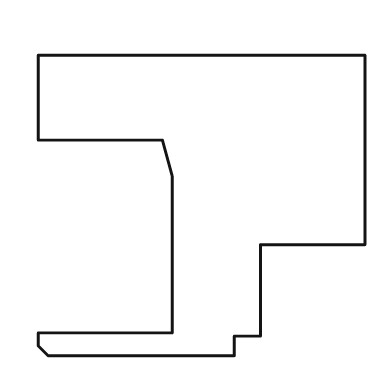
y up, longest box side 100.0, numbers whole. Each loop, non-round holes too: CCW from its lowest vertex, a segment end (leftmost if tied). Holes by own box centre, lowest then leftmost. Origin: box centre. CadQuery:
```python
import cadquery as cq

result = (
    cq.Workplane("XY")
    .moveTo(-47.0, -46.0)
    .lineTo(10.0, -46.0)
    .lineTo(10.0, -40.0)
    .lineTo(18.0, -40.0)
    .lineTo(18.0, -12.0)
    .lineTo(50.0, -12.0)
    .lineTo(50.0, 46.0)
    .lineTo(-50.0, 46.0)
    .lineTo(-50.0, 20.0)
    .lineTo(-12.0, 20.0)
    .lineTo(-9.0, 9.0)
    .lineTo(-9.0, -39.0)
    .lineTo(-50.0, -39.0)
    .lineTo(-50.0, -43.0)
    .close()
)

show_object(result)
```